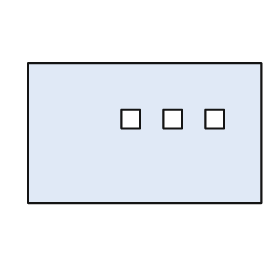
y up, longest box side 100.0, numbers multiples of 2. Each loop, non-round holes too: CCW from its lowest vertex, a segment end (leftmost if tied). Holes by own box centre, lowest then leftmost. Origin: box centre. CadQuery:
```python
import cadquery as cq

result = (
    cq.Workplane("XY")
    .moveTo(-50.0, -30.0)
    .lineTo(50.0, -30.0)
    .lineTo(50.0, 30.0)
    .lineTo(-50.0, 30.0)
    .close()
    .moveTo(-10.0, 2.0)
    .lineTo(-2.0, 2.0)
    .lineTo(-2.0, 10.0)
    .lineTo(-10.0, 10.0)
    .close()
    .moveTo(8.0, 2.0)
    .lineTo(16.0, 2.0)
    .lineTo(16.0, 10.0)
    .lineTo(8.0, 10.0)
    .close()
    .moveTo(26.0, 2.0)
    .lineTo(34.0, 2.0)
    .lineTo(34.0, 10.0)
    .lineTo(26.0, 10.0)
    .close()
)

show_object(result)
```